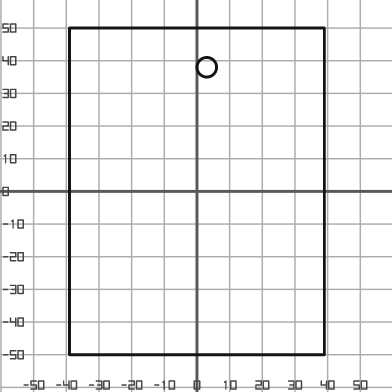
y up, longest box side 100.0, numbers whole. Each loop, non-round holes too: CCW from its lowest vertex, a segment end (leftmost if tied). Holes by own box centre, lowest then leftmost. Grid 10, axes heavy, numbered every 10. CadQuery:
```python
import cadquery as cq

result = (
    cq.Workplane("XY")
    .moveTo(-39.0, -50.0)
    .lineTo(39.0, -50.0)
    .lineTo(39.0, 50.0)
    .lineTo(-39.0, 50.0)
    .close()
    .moveTo(3.0, 38.0)
    .circle(3.0)
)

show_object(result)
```